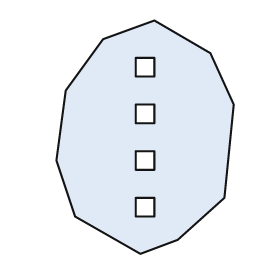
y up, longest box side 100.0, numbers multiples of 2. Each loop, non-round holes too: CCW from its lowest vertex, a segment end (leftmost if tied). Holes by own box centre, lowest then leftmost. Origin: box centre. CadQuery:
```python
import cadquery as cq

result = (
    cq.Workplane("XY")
    .moveTo(-2.0, -50.0)
    .lineTo(14.0, -44.0)
    .lineTo(34.0, -26.0)
    .lineTo(38.0, 14.0)
    .lineTo(28.0, 36.0)
    .lineTo(4.0, 50.0)
    .lineTo(-18.0, 42.0)
    .lineTo(-34.0, 20.0)
    .lineTo(-38.0, -10.0)
    .lineTo(-30.0, -34.0)
    .close()
    .moveTo(-4.0, -34.0)
    .lineTo(4.0, -34.0)
    .lineTo(4.0, -26.0)
    .lineTo(-4.0, -26.0)
    .close()
    .moveTo(-4.0, -14.0)
    .lineTo(4.0, -14.0)
    .lineTo(4.0, -6.0)
    .lineTo(-4.0, -6.0)
    .close()
    .moveTo(-4.0, 6.0)
    .lineTo(4.0, 6.0)
    .lineTo(4.0, 14.0)
    .lineTo(-4.0, 14.0)
    .close()
    .moveTo(-4.0, 26.0)
    .lineTo(4.0, 26.0)
    .lineTo(4.0, 34.0)
    .lineTo(-4.0, 34.0)
    .close()
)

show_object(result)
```